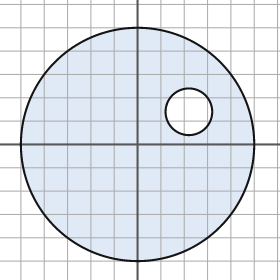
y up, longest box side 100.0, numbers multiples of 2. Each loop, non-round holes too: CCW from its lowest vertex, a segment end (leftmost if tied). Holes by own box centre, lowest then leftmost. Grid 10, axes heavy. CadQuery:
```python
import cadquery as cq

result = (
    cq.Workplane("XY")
    .moveTo(0.0, 0.0)
    .circle(50.0)
    .moveTo(22.0, 14.0)
    .circle(10.0)
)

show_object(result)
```